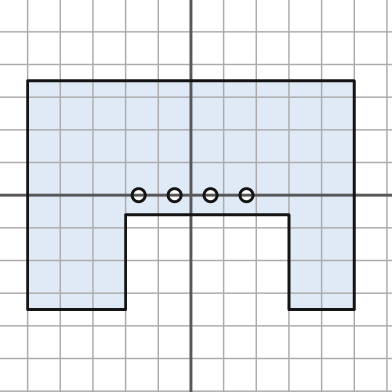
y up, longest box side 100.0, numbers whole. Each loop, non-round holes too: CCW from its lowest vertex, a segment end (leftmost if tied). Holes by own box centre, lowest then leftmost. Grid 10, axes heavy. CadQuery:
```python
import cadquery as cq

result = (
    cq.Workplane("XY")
    .moveTo(-50.0, -35.0)
    .lineTo(-20.0, -35.0)
    .lineTo(-20.0, -6.0)
    .lineTo(30.0, -6.0)
    .lineTo(30.0, -35.0)
    .lineTo(50.0, -35.0)
    .lineTo(50.0, 35.0)
    .lineTo(-50.0, 35.0)
    .close()
    .moveTo(-16.0, 0.0)
    .circle(2.0)
    .moveTo(-5.0, 0.0)
    .circle(2.0)
    .moveTo(6.0, 0.0)
    .circle(2.0)
    .moveTo(17.0, 0.0)
    .circle(2.0)
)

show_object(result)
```